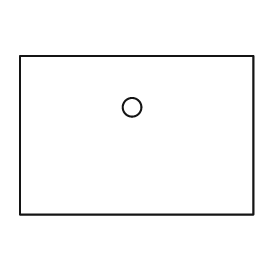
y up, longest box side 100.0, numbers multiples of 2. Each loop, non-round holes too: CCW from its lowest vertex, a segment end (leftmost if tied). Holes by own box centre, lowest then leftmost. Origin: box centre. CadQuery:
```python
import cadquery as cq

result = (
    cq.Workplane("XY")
    .moveTo(-50.0, -34.0)
    .lineTo(50.0, -34.0)
    .lineTo(50.0, 34.0)
    .lineTo(-50.0, 34.0)
    .close()
    .moveTo(-2.0, 12.0)
    .circle(4.0)
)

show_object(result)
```